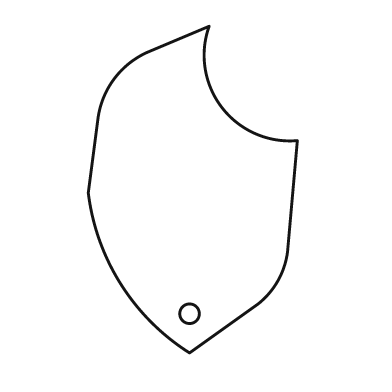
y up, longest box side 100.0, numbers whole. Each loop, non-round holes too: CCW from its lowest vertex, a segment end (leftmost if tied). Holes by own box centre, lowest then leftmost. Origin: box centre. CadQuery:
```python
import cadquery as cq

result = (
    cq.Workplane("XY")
    .moveTo(-1.0, -50.0)
    .lineTo(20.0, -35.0)
    .threePointArc((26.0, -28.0), (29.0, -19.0))
    .lineTo(32.0, 15.0)
    .threePointArc((9.0, 25.0), (5.0, 50.0))
    .lineTo(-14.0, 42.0)
    .threePointArc((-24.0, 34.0), (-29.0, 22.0))
    .lineTo(-32.0, -1.0)
    .threePointArc((-22.0, -29.0), (-1.0, -50.0))
    .close()
    .moveTo(-1.0, -38.0)
    .circle(3.0)
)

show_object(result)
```